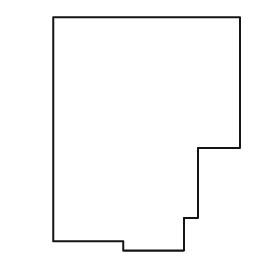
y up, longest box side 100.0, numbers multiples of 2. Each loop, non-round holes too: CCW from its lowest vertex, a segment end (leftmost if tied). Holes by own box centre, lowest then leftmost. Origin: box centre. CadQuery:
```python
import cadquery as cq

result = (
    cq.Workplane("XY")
    .moveTo(-10.0, -50.0)
    .lineTo(16.0, -50.0)
    .lineTo(16.0, -36.0)
    .lineTo(22.0, -36.0)
    .lineTo(22.0, -6.0)
    .lineTo(40.0, -6.0)
    .lineTo(40.0, 50.0)
    .lineTo(-40.0, 50.0)
    .lineTo(-40.0, -46.0)
    .lineTo(-10.0, -46.0)
    .close()
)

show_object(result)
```